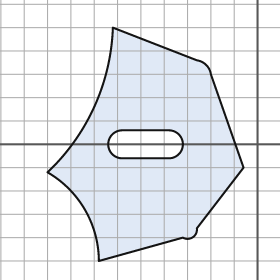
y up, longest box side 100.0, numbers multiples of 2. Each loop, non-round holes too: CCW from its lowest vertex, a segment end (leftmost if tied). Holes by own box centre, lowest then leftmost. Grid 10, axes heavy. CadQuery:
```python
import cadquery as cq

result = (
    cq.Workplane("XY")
    .moveTo(-68.0, -50.0)
    .lineTo(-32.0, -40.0)
    .threePointArc((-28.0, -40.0), (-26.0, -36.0))
    .lineTo(-6.0, -10.0)
    .lineTo(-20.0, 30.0)
    .threePointArc((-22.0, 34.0), (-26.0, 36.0))
    .lineTo(-62.0, 50.0)
    .threePointArc((-70.0, 16.0), (-90.0, -12.0))
    .threePointArc((-74.0, -28.0), (-68.0, -50.0))
    .close()
    .moveTo(-58.0, -6.0)
    .lineTo(-38.0, -6.0)
    .threePointArc((-32.0, 0.0), (-38.0, 6.0))
    .lineTo(-58.0, 6.0)
    .threePointArc((-64.0, 0.0), (-58.0, -6.0))
    .close()
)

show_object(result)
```